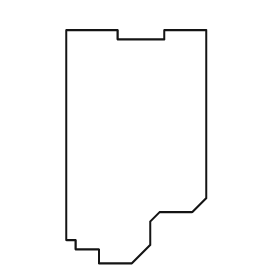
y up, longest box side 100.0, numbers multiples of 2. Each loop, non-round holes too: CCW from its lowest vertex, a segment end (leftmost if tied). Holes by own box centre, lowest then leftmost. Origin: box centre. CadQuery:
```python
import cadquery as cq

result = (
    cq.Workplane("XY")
    .moveTo(-16.0, -50.0)
    .lineTo(-2.0, -50.0)
    .lineTo(6.0, -42.0)
    .lineTo(6.0, -32.0)
    .lineTo(10.0, -28.0)
    .lineTo(24.0, -28.0)
    .lineTo(30.0, -22.0)
    .lineTo(30.0, 50.0)
    .lineTo(12.0, 50.0)
    .lineTo(12.0, 46.0)
    .lineTo(-8.0, 46.0)
    .lineTo(-8.0, 50.0)
    .lineTo(-30.0, 50.0)
    .lineTo(-30.0, -40.0)
    .lineTo(-26.0, -40.0)
    .lineTo(-26.0, -44.0)
    .lineTo(-16.0, -44.0)
    .close()
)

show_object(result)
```